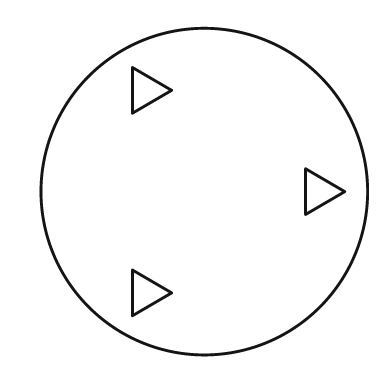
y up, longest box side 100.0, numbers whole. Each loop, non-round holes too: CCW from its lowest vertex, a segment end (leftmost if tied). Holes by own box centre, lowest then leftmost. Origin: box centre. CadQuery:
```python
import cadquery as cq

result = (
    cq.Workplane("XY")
    .moveTo(0.0, 0.0)
    .circle(50.0)
    .moveTo(-22.0, -38.0)
    .lineTo(-10.0, -31.0)
    .lineTo(-22.0, -24.0)
    .close()
    .moveTo(31.0, -7.0)
    .lineTo(43.0, 0.0)
    .lineTo(31.0, 7.0)
    .close()
    .moveTo(-22.0, 24.0)
    .lineTo(-10.0, 31.0)
    .lineTo(-22.0, 38.0)
    .close()
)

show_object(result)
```